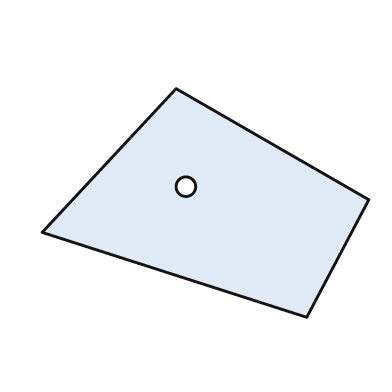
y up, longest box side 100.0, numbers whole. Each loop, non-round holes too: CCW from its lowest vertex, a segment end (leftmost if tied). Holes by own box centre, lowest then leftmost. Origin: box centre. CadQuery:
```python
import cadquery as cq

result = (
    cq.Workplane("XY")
    .moveTo(31.0, -35.0)
    .lineTo(50.0, 1.0)
    .lineTo(-9.0, 35.0)
    .lineTo(-50.0, -9.0)
    .close()
    .moveTo(-6.0, 5.0)
    .circle(3.0)
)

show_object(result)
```